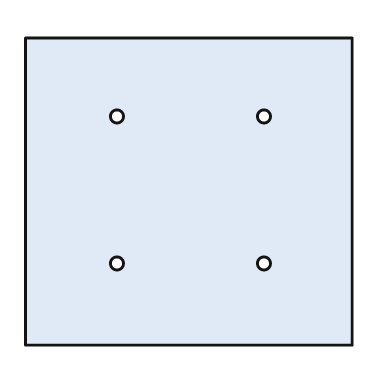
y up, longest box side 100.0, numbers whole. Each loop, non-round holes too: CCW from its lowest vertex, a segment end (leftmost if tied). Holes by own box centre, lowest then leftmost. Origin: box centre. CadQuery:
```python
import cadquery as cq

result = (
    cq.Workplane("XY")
    .moveTo(-50.0, -47.0)
    .lineTo(50.0, -47.0)
    .lineTo(50.0, 47.0)
    .lineTo(-50.0, 47.0)
    .close()
    .moveTo(-22.0, -22.0)
    .circle(2.0)
    .moveTo(23.0, -22.0)
    .circle(2.0)
    .moveTo(-22.0, 23.0)
    .circle(2.0)
    .moveTo(23.0, 23.0)
    .circle(2.0)
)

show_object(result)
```